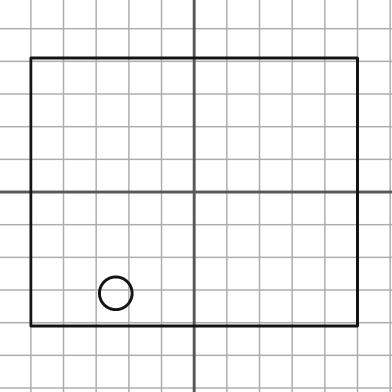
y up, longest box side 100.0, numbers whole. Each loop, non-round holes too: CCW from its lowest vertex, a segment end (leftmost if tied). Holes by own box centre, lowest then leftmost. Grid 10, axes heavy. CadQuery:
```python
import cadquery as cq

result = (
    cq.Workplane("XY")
    .moveTo(-50.0, -41.0)
    .lineTo(50.0, -41.0)
    .lineTo(50.0, 41.0)
    .lineTo(-50.0, 41.0)
    .close()
    .moveTo(-24.0, -31.0)
    .circle(5.0)
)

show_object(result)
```